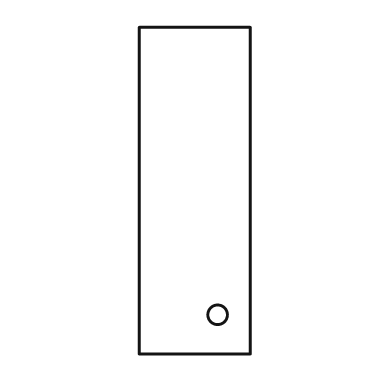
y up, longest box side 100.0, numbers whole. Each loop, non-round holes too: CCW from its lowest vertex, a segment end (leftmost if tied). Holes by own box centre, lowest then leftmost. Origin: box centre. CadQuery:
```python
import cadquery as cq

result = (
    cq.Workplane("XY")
    .moveTo(-17.0, -50.0)
    .lineTo(17.0, -50.0)
    .lineTo(17.0, 50.0)
    .lineTo(-17.0, 50.0)
    .close()
    .moveTo(7.0, -38.0)
    .circle(3.0)
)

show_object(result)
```